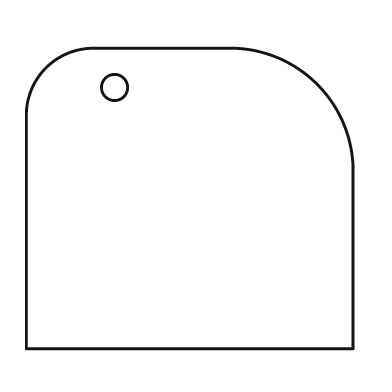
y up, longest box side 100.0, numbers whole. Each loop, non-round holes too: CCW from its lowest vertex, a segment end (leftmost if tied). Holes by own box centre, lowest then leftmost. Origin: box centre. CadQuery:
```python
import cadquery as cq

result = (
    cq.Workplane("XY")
    .moveTo(-50.0, -46.0)
    .lineTo(50.0, -46.0)
    .lineTo(50.0, 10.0)
    .threePointArc((39.0, 35.0), (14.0, 46.0))
    .lineTo(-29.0, 46.0)
    .threePointArc((-44.0, 40.0), (-50.0, 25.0))
    .close()
    .moveTo(-23.0, 34.0)
    .circle(4.0)
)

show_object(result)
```